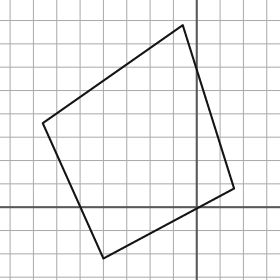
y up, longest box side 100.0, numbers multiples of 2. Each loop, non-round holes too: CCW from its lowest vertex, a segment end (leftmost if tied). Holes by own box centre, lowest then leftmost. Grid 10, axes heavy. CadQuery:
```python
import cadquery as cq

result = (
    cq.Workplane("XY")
    .moveTo(-40.0, -22.0)
    .lineTo(16.0, 8.0)
    .lineTo(-6.0, 78.0)
    .lineTo(-66.0, 36.0)
    .close()
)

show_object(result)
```